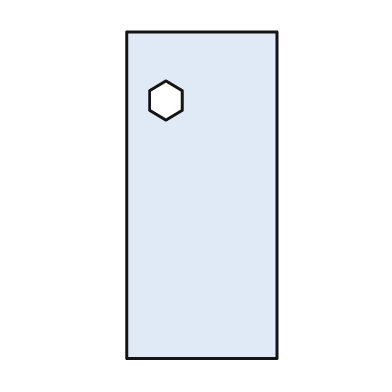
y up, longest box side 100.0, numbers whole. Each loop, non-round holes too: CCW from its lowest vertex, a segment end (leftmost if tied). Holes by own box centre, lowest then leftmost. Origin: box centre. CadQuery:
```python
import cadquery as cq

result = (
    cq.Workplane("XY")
    .moveTo(-23.0, -50.0)
    .lineTo(23.0, -50.0)
    .lineTo(23.0, 50.0)
    .lineTo(-23.0, 50.0)
    .close()
    .moveTo(-11.0, 23.0)
    .lineTo(-6.0, 26.0)
    .lineTo(-6.0, 32.0)
    .lineTo(-11.0, 35.0)
    .lineTo(-16.0, 32.0)
    .lineTo(-16.0, 26.0)
    .close()
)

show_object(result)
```